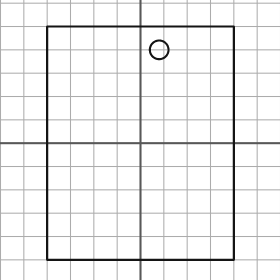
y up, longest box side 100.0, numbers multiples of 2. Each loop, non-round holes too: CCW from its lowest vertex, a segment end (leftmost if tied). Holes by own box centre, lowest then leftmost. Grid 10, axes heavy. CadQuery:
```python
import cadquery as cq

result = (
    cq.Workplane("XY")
    .moveTo(-40.0, -50.0)
    .lineTo(40.0, -50.0)
    .lineTo(40.0, 50.0)
    .lineTo(-40.0, 50.0)
    .close()
    .moveTo(8.0, 40.0)
    .circle(4.0)
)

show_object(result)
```